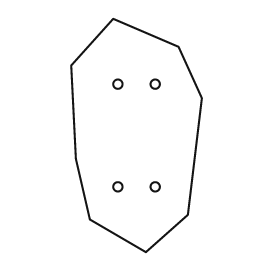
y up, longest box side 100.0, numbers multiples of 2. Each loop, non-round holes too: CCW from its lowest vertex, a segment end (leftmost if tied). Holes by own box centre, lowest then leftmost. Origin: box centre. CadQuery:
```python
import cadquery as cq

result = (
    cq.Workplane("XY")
    .moveTo(4.0, -50.0)
    .lineTo(22.0, -34.0)
    .lineTo(28.0, 16.0)
    .lineTo(18.0, 38.0)
    .lineTo(-10.0, 50.0)
    .lineTo(-28.0, 30.0)
    .lineTo(-26.0, -10.0)
    .lineTo(-20.0, -36.0)
    .close()
    .moveTo(-8.0, -22.0)
    .circle(2.0)
    .moveTo(8.0, -22.0)
    .circle(2.0)
    .moveTo(-8.0, 22.0)
    .circle(2.0)
    .moveTo(8.0, 22.0)
    .circle(2.0)
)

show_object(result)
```